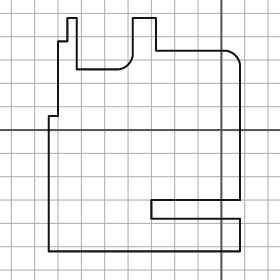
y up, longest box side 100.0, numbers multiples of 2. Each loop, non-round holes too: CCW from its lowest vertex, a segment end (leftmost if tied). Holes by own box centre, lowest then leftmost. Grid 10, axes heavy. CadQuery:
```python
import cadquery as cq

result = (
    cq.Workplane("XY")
    .moveTo(-74.0, -52.0)
    .lineTo(8.0, -52.0)
    .lineTo(8.0, -38.0)
    .lineTo(-30.0, -38.0)
    .lineTo(-30.0, -30.0)
    .lineTo(8.0, -30.0)
    .lineTo(8.0, 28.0)
    .threePointArc((6.0, 32.0), (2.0, 34.0))
    .lineTo(-28.0, 34.0)
    .lineTo(-28.0, 48.0)
    .lineTo(-38.0, 48.0)
    .lineTo(-38.0, 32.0)
    .threePointArc((-40.0, 28.0), (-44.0, 26.0))
    .lineTo(-62.0, 26.0)
    .lineTo(-62.0, 48.0)
    .lineTo(-66.0, 48.0)
    .lineTo(-66.0, 38.0)
    .lineTo(-70.0, 38.0)
    .lineTo(-70.0, 6.0)
    .lineTo(-74.0, 6.0)
    .close()
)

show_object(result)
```